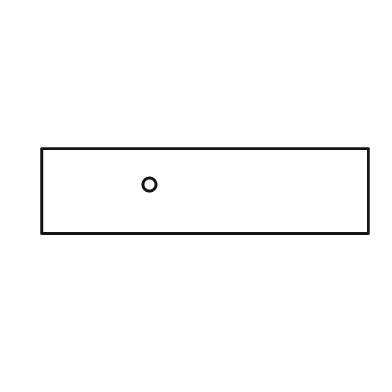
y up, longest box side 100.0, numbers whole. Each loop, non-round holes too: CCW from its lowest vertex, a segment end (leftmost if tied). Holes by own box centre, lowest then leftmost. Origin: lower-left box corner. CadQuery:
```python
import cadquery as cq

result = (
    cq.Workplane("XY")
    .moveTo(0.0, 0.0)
    .lineTo(100.0, 0.0)
    .lineTo(100.0, 26.0)
    .lineTo(0.0, 26.0)
    .close()
    .moveTo(33.0, 15.0)
    .circle(2.0)
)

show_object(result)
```